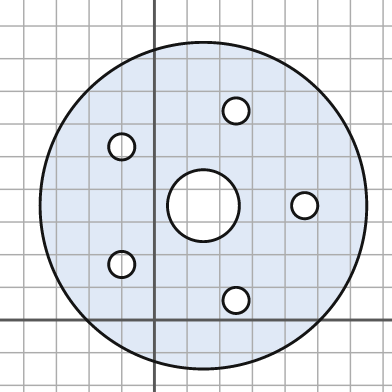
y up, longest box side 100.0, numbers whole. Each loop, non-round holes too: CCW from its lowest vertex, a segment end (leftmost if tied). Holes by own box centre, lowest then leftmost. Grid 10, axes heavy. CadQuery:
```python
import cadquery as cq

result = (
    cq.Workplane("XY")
    .moveTo(15.0, 35.0)
    .circle(50.0)
    .moveTo(25.0, 6.0)
    .circle(4.0)
    .moveTo(-10.0, 17.0)
    .circle(4.0)
    .moveTo(15.0, 35.0)
    .circle(11.0)
    .moveTo(46.0, 35.0)
    .circle(4.0)
    .moveTo(-10.0, 53.0)
    .circle(4.0)
    .moveTo(25.0, 64.0)
    .circle(4.0)
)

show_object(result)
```